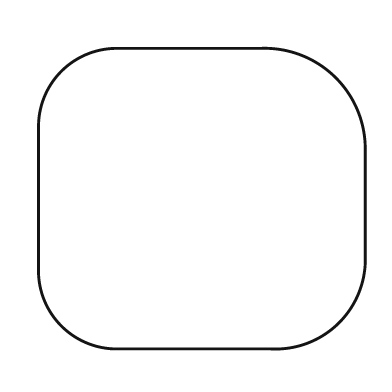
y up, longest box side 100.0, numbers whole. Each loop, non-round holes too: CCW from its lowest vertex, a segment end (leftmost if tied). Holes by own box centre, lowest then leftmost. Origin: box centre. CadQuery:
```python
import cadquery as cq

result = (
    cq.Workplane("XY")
    .moveTo(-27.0, -46.0)
    .lineTo(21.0, -46.0)
    .threePointArc((42.0, -38.0), (50.0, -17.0))
    .lineTo(50.0, 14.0)
    .threePointArc((41.0, 37.0), (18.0, 46.0))
    .lineTo(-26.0, 46.0)
    .threePointArc((-43.0, 39.0), (-50.0, 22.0))
    .lineTo(-50.0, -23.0)
    .threePointArc((-43.0, -39.0), (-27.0, -46.0))
    .close()
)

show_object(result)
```